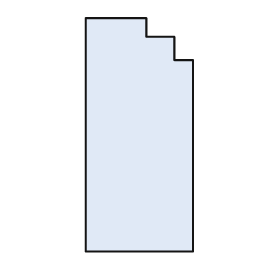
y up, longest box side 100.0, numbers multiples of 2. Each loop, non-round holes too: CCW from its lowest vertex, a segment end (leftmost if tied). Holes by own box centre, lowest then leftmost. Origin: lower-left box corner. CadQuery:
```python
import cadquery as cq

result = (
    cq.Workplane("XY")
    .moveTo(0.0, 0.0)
    .lineTo(46.0, 0.0)
    .lineTo(46.0, 82.0)
    .lineTo(38.0, 82.0)
    .lineTo(38.0, 92.0)
    .lineTo(26.0, 92.0)
    .lineTo(26.0, 100.0)
    .lineTo(0.0, 100.0)
    .close()
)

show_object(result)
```